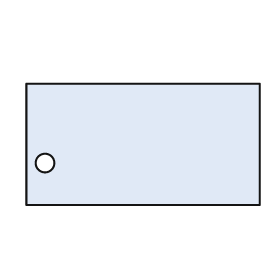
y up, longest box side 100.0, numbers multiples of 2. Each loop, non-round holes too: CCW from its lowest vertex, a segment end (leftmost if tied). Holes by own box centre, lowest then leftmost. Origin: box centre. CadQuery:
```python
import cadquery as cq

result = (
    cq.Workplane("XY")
    .moveTo(-50.0, -26.0)
    .lineTo(50.0, -26.0)
    .lineTo(50.0, 26.0)
    .lineTo(-50.0, 26.0)
    .close()
    .moveTo(-42.0, -8.0)
    .circle(4.0)
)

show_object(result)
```